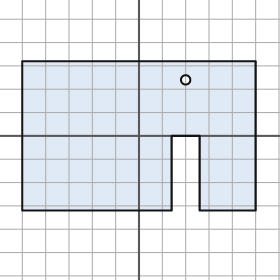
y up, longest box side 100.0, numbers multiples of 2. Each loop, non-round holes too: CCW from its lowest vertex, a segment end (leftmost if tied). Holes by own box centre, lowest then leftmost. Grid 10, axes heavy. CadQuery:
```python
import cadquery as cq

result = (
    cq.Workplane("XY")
    .moveTo(-50.0, -32.0)
    .lineTo(14.0, -32.0)
    .lineTo(14.0, 0.0)
    .lineTo(26.0, 0.0)
    .lineTo(26.0, -32.0)
    .lineTo(50.0, -32.0)
    .lineTo(50.0, 32.0)
    .lineTo(-50.0, 32.0)
    .close()
    .moveTo(20.0, 24.0)
    .circle(2.0)
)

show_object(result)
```